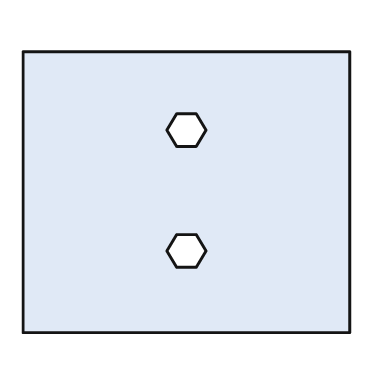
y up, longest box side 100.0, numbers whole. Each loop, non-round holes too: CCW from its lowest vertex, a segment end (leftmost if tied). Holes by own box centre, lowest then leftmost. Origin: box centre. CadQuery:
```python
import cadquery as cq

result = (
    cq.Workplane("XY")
    .moveTo(-50.0, -43.0)
    .lineTo(50.0, -43.0)
    .lineTo(50.0, 43.0)
    .lineTo(-50.0, 43.0)
    .close()
    .moveTo(-3.0, -23.0)
    .lineTo(3.0, -23.0)
    .lineTo(6.0, -18.0)
    .lineTo(3.0, -13.0)
    .lineTo(-3.0, -13.0)
    .lineTo(-6.0, -18.0)
    .close()
    .moveTo(-3.0, 14.0)
    .lineTo(3.0, 14.0)
    .lineTo(6.0, 19.0)
    .lineTo(3.0, 24.0)
    .lineTo(-3.0, 24.0)
    .lineTo(-6.0, 19.0)
    .close()
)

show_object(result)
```